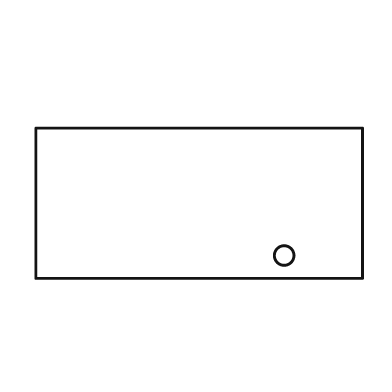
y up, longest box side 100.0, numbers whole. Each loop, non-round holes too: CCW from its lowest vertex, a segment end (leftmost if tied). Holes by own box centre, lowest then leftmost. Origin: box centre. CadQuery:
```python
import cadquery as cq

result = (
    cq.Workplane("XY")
    .moveTo(-50.0, -23.0)
    .lineTo(50.0, -23.0)
    .lineTo(50.0, 23.0)
    .lineTo(-50.0, 23.0)
    .close()
    .moveTo(26.0, -16.0)
    .circle(3.0)
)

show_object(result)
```